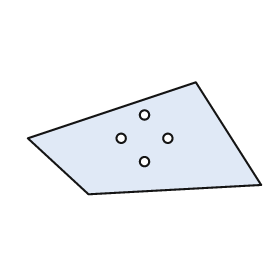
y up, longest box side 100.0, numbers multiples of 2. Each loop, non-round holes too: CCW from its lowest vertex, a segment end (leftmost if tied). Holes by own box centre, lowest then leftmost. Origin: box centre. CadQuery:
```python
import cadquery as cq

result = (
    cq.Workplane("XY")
    .moveTo(-24.0, -24.0)
    .lineTo(50.0, -20.0)
    .lineTo(22.0, 24.0)
    .lineTo(-50.0, 0.0)
    .close()
    .moveTo(0.0, -10.0)
    .circle(2.0)
    .moveTo(-10.0, 0.0)
    .circle(2.0)
    .moveTo(10.0, 0.0)
    .circle(2.0)
    .moveTo(0.0, 10.0)
    .circle(2.0)
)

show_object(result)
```